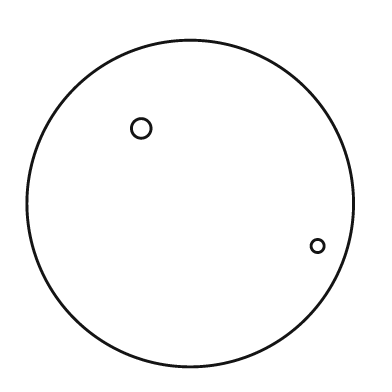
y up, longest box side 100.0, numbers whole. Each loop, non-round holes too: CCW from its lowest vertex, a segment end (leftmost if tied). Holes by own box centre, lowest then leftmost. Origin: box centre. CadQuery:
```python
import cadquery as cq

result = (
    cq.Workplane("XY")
    .moveTo(0.0, 0.0)
    .circle(50.0)
    .moveTo(39.0, -13.0)
    .circle(2.0)
    .moveTo(-15.0, 23.0)
    .circle(3.0)
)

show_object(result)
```